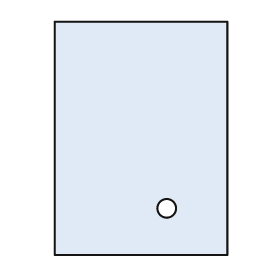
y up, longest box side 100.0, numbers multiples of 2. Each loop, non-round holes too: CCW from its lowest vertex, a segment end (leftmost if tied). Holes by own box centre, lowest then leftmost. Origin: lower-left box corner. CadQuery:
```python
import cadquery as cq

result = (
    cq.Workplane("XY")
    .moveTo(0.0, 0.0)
    .lineTo(74.0, 0.0)
    .lineTo(74.0, 100.0)
    .lineTo(0.0, 100.0)
    .close()
    .moveTo(48.0, 20.0)
    .circle(4.0)
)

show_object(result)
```